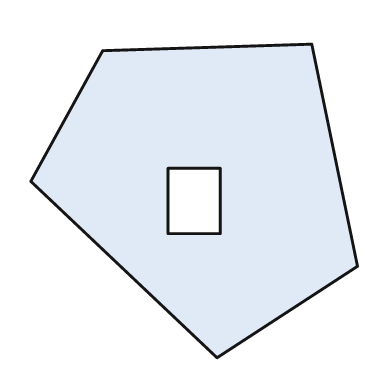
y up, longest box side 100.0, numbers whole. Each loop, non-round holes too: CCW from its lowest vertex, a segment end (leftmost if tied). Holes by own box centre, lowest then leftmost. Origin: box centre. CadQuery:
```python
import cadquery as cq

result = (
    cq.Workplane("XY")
    .moveTo(7.0, -48.0)
    .lineTo(50.0, -20.0)
    .lineTo(36.0, 48.0)
    .lineTo(-28.0, 46.0)
    .lineTo(-50.0, 6.0)
    .close()
    .moveTo(-8.0, -10.0)
    .lineTo(8.0, -10.0)
    .lineTo(8.0, 10.0)
    .lineTo(-8.0, 10.0)
    .close()
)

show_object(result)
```